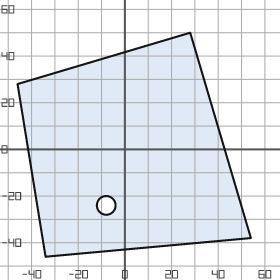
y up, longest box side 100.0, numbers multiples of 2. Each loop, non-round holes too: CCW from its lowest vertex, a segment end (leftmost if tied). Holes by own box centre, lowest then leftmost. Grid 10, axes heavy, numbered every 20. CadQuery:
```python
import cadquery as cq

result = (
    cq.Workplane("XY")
    .moveTo(-34.0, -46.0)
    .lineTo(54.0, -38.0)
    .lineTo(28.0, 50.0)
    .lineTo(-46.0, 28.0)
    .close()
    .moveTo(-8.0, -24.0)
    .circle(4.0)
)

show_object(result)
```